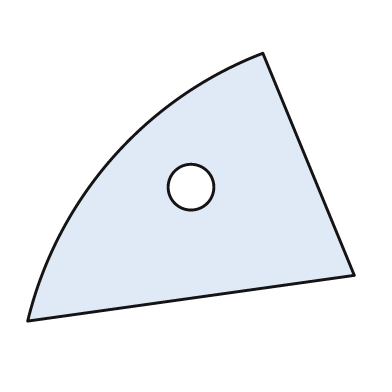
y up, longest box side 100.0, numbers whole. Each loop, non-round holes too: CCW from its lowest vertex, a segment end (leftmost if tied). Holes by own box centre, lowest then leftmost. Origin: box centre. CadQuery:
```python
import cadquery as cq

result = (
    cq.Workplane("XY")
    .moveTo(-50.0, -41.0)
    .lineTo(50.0, -27.0)
    .lineTo(22.0, 41.0)
    .threePointArc((-24.0, 9.0), (-50.0, -41.0))
    .close()
    .moveTo(0.0, 0.0)
    .circle(7.0)
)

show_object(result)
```